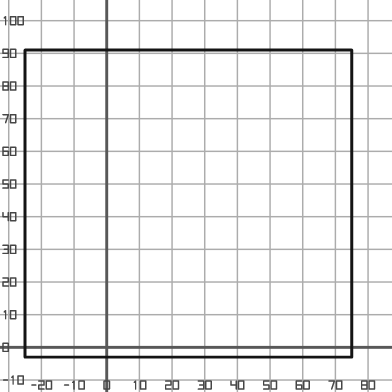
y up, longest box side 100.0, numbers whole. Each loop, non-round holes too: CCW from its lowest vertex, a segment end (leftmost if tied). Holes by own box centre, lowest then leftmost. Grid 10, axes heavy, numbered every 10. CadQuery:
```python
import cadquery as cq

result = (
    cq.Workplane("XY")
    .moveTo(-25.0, -3.0)
    .lineTo(75.0, -3.0)
    .lineTo(75.0, 91.0)
    .lineTo(-25.0, 91.0)
    .close()
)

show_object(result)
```